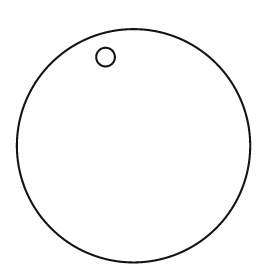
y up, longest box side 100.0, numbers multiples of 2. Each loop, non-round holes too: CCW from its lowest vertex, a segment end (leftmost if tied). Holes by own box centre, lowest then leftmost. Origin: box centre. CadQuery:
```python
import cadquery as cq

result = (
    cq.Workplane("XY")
    .moveTo(0.0, 0.0)
    .circle(50.0)
    .moveTo(-12.0, 38.0)
    .circle(4.0)
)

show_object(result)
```